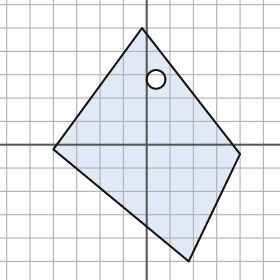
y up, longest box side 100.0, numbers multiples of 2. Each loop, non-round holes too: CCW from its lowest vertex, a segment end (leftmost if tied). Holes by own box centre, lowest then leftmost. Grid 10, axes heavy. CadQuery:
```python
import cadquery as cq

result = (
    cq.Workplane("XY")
    .moveTo(18.0, -50.0)
    .lineTo(40.0, -4.0)
    .lineTo(-2.0, 50.0)
    .lineTo(-40.0, -2.0)
    .close()
    .moveTo(4.0, 28.0)
    .circle(4.0)
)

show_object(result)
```